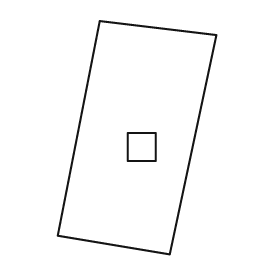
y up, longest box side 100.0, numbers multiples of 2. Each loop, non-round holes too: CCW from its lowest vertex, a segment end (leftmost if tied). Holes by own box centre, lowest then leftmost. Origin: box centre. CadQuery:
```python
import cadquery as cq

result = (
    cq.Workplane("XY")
    .moveTo(14.0, -50.0)
    .lineTo(34.0, 44.0)
    .lineTo(-16.0, 50.0)
    .lineTo(-34.0, -42.0)
    .close()
    .moveTo(-4.0, -10.0)
    .lineTo(8.0, -10.0)
    .lineTo(8.0, 2.0)
    .lineTo(-4.0, 2.0)
    .close()
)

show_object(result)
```